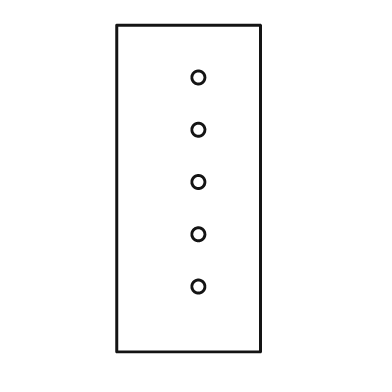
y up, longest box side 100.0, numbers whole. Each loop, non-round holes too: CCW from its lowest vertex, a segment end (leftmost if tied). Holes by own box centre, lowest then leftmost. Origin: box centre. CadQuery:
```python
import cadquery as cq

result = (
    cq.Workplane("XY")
    .moveTo(-22.0, -50.0)
    .lineTo(22.0, -50.0)
    .lineTo(22.0, 50.0)
    .lineTo(-22.0, 50.0)
    .close()
    .moveTo(3.0, -30.0)
    .circle(2.0)
    .moveTo(3.0, -14.0)
    .circle(2.0)
    .moveTo(3.0, 2.0)
    .circle(2.0)
    .moveTo(3.0, 18.0)
    .circle(2.0)
    .moveTo(3.0, 34.0)
    .circle(2.0)
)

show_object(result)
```